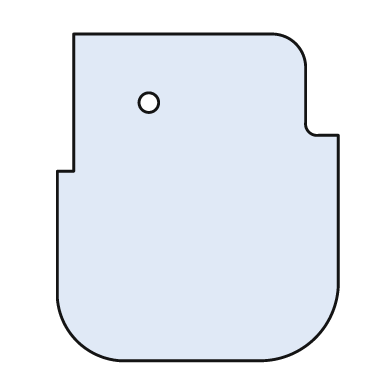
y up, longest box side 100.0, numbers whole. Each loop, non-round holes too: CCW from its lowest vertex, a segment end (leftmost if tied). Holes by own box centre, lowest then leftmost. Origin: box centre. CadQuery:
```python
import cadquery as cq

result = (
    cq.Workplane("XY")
    .moveTo(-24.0, -50.0)
    .lineTo(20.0, -50.0)
    .threePointArc((36.0, -43.0), (43.0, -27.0))
    .lineTo(43.0, 19.0)
    .lineTo(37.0, 19.0)
    .threePointArc((34.0, 20.0), (33.0, 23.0))
    .lineTo(33.0, 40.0)
    .threePointArc((30.0, 47.0), (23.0, 50.0))
    .lineTo(-38.0, 50.0)
    .lineTo(-38.0, 8.0)
    .lineTo(-43.0, 8.0)
    .lineTo(-43.0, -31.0)
    .threePointArc((-37.0, -44.0), (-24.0, -50.0))
    .close()
    .moveTo(-15.0, 29.0)
    .circle(3.0)
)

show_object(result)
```